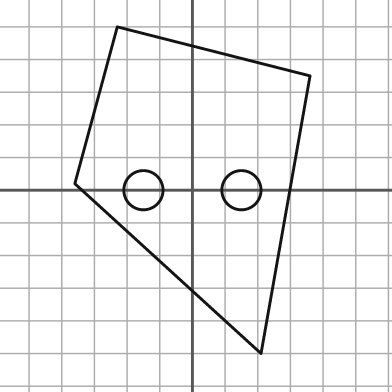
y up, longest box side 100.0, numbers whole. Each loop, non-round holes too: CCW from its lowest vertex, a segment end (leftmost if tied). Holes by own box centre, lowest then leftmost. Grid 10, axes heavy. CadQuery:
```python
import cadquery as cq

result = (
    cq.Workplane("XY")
    .moveTo(21.0, -50.0)
    .lineTo(36.0, 35.0)
    .lineTo(-23.0, 50.0)
    .lineTo(-36.0, 2.0)
    .close()
    .moveTo(-15.0, 0.0)
    .circle(6.0)
    .moveTo(15.0, 0.0)
    .circle(6.0)
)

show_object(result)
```